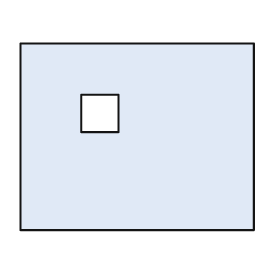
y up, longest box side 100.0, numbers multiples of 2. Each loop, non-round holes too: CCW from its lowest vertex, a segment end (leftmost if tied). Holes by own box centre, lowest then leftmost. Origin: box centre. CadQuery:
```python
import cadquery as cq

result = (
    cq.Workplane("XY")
    .moveTo(-50.0, -40.0)
    .lineTo(50.0, -40.0)
    .lineTo(50.0, 40.0)
    .lineTo(-50.0, 40.0)
    .close()
    .moveTo(-24.0, 2.0)
    .lineTo(-8.0, 2.0)
    .lineTo(-8.0, 18.0)
    .lineTo(-24.0, 18.0)
    .close()
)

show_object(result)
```